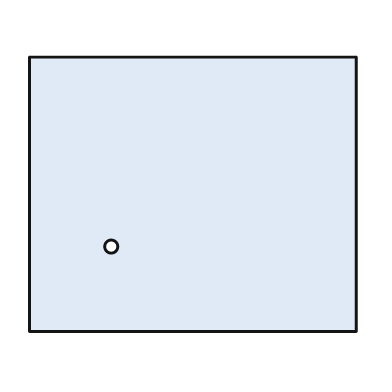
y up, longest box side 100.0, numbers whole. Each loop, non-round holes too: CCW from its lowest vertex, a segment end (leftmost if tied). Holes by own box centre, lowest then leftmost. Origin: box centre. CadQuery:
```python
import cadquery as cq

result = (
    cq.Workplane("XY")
    .moveTo(-50.0, -42.0)
    .lineTo(50.0, -42.0)
    .lineTo(50.0, 42.0)
    .lineTo(-50.0, 42.0)
    .close()
    .moveTo(-25.0, -16.0)
    .circle(2.0)
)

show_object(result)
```